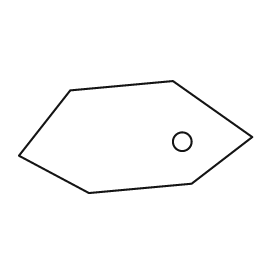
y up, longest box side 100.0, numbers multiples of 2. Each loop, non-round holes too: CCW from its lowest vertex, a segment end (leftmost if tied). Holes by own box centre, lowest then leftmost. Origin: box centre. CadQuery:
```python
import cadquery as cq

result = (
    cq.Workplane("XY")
    .moveTo(-20.0, -24.0)
    .lineTo(24.0, -20.0)
    .lineTo(50.0, 0.0)
    .lineTo(16.0, 24.0)
    .lineTo(-28.0, 20.0)
    .lineTo(-50.0, -8.0)
    .close()
    .moveTo(20.0, -2.0)
    .circle(4.0)
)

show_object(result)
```